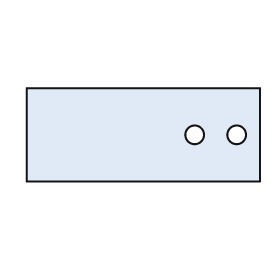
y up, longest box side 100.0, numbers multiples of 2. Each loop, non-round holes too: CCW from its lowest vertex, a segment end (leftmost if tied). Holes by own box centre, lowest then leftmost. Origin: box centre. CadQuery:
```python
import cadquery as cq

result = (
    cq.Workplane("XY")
    .moveTo(-50.0, -20.0)
    .lineTo(50.0, -20.0)
    .lineTo(50.0, 20.0)
    .lineTo(-50.0, 20.0)
    .close()
    .moveTo(22.0, 0.0)
    .circle(4.0)
    .moveTo(40.0, 0.0)
    .circle(4.0)
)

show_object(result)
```